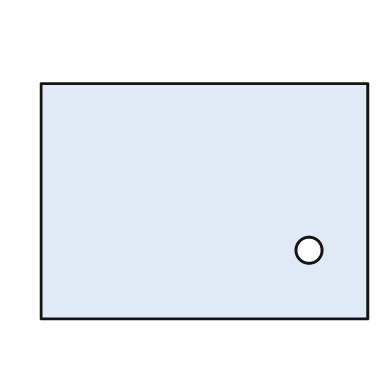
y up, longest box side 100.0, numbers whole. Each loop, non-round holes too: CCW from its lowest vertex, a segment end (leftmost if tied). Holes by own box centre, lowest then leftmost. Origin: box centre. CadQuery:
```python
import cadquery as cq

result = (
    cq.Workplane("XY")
    .moveTo(-50.0, -36.0)
    .lineTo(50.0, -36.0)
    .lineTo(50.0, 36.0)
    .lineTo(-50.0, 36.0)
    .close()
    .moveTo(32.0, -15.0)
    .circle(4.0)
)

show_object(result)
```